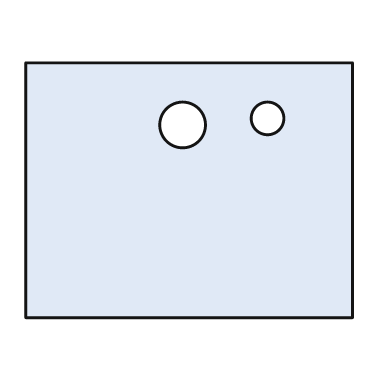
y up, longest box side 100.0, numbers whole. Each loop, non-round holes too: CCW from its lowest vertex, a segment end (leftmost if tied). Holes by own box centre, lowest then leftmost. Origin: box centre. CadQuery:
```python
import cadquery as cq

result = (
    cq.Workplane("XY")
    .moveTo(-50.0, -39.0)
    .lineTo(50.0, -39.0)
    .lineTo(50.0, 39.0)
    .lineTo(-50.0, 39.0)
    .close()
    .moveTo(-2.0, 20.0)
    .circle(7.0)
    .moveTo(24.0, 22.0)
    .circle(5.0)
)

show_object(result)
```